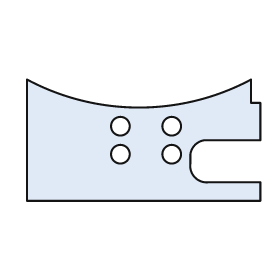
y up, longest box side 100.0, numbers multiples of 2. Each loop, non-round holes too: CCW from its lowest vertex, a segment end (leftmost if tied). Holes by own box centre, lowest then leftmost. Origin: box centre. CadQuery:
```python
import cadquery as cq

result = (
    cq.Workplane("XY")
    .moveTo(-50.0, -26.0)
    .lineTo(50.0, -26.0)
    .lineTo(50.0, -18.0)
    .lineTo(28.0, -18.0)
    .threePointArc((22.0, -16.0), (20.0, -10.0))
    .lineTo(20.0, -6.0)
    .threePointArc((22.0, -2.0), (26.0, 0.0))
    .lineTo(50.0, 0.0)
    .lineTo(50.0, 16.0)
    .lineTo(46.0, 16.0)
    .lineTo(46.0, 26.0)
    .threePointArc((-2.0, 14.0), (-50.0, 26.0))
    .close()
    .moveTo(-10.0, -6.0)
    .circle(4.0)
    .moveTo(12.0, -6.0)
    .circle(4.0)
    .moveTo(-10.0, 6.0)
    .circle(4.0)
    .moveTo(12.0, 6.0)
    .circle(4.0)
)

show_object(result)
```